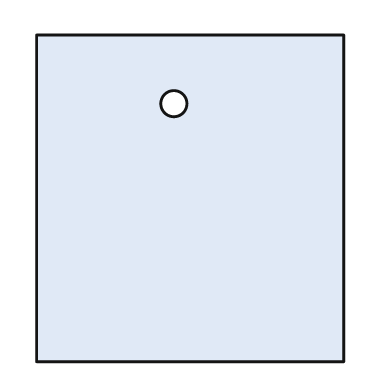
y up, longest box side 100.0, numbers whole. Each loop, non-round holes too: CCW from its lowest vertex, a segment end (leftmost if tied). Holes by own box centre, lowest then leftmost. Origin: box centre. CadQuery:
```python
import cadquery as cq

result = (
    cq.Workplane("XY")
    .moveTo(-47.0, -50.0)
    .lineTo(47.0, -50.0)
    .lineTo(47.0, 50.0)
    .lineTo(-47.0, 50.0)
    .close()
    .moveTo(-5.0, 29.0)
    .circle(4.0)
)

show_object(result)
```